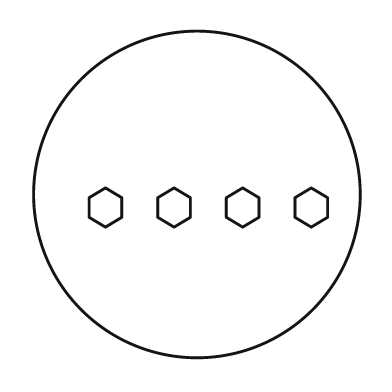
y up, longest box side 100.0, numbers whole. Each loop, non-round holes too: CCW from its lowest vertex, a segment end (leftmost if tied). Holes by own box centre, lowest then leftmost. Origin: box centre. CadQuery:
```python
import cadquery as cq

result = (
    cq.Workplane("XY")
    .moveTo(0.0, 0.0)
    .circle(50.0)
    .moveTo(-28.0, -10.0)
    .lineTo(-23.0, -7.0)
    .lineTo(-23.0, -1.0)
    .lineTo(-28.0, 2.0)
    .lineTo(-33.0, -1.0)
    .lineTo(-33.0, -7.0)
    .close()
    .moveTo(-7.0, -10.0)
    .lineTo(-2.0, -7.0)
    .lineTo(-2.0, -1.0)
    .lineTo(-7.0, 2.0)
    .lineTo(-12.0, -1.0)
    .lineTo(-12.0, -7.0)
    .close()
    .moveTo(14.0, -10.0)
    .lineTo(19.0, -7.0)
    .lineTo(19.0, -1.0)
    .lineTo(14.0, 2.0)
    .lineTo(9.0, -1.0)
    .lineTo(9.0, -7.0)
    .close()
    .moveTo(35.0, -10.0)
    .lineTo(40.0, -7.0)
    .lineTo(40.0, -1.0)
    .lineTo(35.0, 2.0)
    .lineTo(30.0, -1.0)
    .lineTo(30.0, -7.0)
    .close()
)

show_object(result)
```